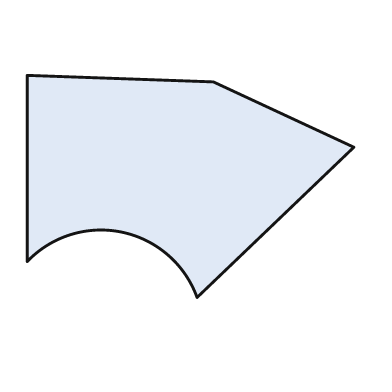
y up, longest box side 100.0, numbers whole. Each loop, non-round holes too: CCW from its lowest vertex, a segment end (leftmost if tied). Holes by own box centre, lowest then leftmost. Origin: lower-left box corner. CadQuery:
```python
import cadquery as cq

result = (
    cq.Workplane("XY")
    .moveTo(52.0, 0.0)
    .lineTo(100.0, 46.0)
    .lineTo(57.0, 66.0)
    .lineTo(0.0, 68.0)
    .lineTo(0.0, 11.0)
    .threePointArc((29.0, 20.0), (52.0, 0.0))
    .close()
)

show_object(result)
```